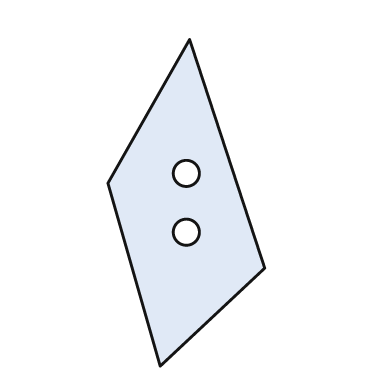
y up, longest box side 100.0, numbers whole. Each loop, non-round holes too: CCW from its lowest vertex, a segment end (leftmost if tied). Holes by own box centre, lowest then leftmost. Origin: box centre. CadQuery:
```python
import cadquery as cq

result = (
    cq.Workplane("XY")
    .moveTo(-8.0, -50.0)
    .lineTo(24.0, -20.0)
    .lineTo(1.0, 50.0)
    .lineTo(-24.0, 6.0)
    .close()
    .moveTo(0.0, -9.0)
    .circle(4.0)
    .moveTo(0.0, 9.0)
    .circle(4.0)
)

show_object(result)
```